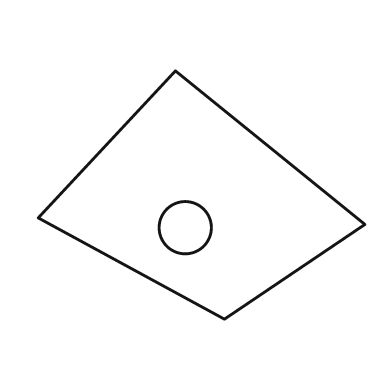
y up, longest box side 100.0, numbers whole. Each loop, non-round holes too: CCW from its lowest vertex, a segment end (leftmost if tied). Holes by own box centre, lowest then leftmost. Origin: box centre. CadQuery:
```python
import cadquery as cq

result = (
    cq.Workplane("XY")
    .moveTo(7.0, -38.0)
    .lineTo(50.0, -9.0)
    .lineTo(-8.0, 38.0)
    .lineTo(-50.0, -7.0)
    .close()
    .moveTo(-5.0, -10.0)
    .circle(8.0)
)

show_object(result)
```